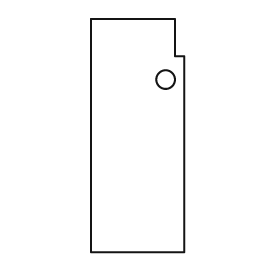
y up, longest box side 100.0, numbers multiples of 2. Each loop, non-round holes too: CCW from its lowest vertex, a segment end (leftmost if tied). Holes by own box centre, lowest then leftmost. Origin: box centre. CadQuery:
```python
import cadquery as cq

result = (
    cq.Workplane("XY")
    .moveTo(-20.0, -50.0)
    .lineTo(20.0, -50.0)
    .lineTo(20.0, 34.0)
    .lineTo(16.0, 34.0)
    .lineTo(16.0, 50.0)
    .lineTo(-20.0, 50.0)
    .close()
    .moveTo(12.0, 24.0)
    .circle(4.0)
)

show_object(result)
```